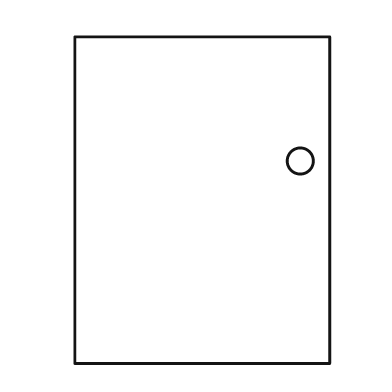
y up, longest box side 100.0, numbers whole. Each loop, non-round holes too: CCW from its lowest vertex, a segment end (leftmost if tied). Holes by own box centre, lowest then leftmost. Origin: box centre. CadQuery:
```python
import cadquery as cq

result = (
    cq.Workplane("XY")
    .moveTo(-39.0, -50.0)
    .lineTo(39.0, -50.0)
    .lineTo(39.0, 50.0)
    .lineTo(-39.0, 50.0)
    .close()
    .moveTo(30.0, 12.0)
    .circle(4.0)
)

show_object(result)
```